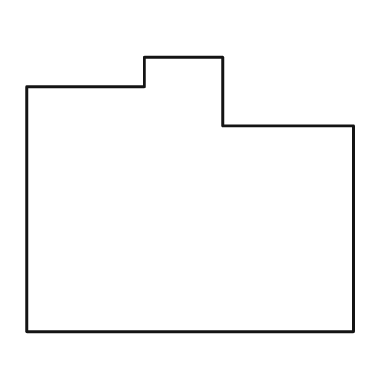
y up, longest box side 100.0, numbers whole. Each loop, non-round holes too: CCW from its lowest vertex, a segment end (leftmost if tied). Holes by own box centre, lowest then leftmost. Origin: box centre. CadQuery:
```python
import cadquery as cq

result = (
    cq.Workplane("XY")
    .moveTo(-50.0, -42.0)
    .lineTo(50.0, -42.0)
    .lineTo(50.0, 21.0)
    .lineTo(10.0, 21.0)
    .lineTo(10.0, 42.0)
    .lineTo(-14.0, 42.0)
    .lineTo(-14.0, 33.0)
    .lineTo(-50.0, 33.0)
    .close()
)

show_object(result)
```